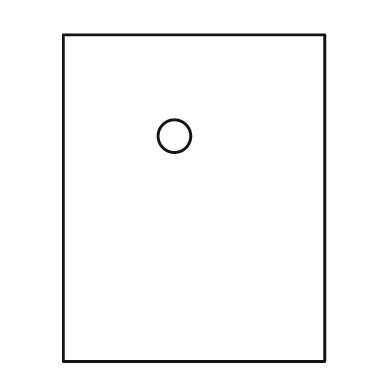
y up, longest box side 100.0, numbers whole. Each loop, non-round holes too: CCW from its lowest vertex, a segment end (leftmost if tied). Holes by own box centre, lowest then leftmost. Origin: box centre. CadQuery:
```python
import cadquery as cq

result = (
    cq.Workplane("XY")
    .moveTo(-40.0, -50.0)
    .lineTo(40.0, -50.0)
    .lineTo(40.0, 50.0)
    .lineTo(-40.0, 50.0)
    .close()
    .moveTo(-6.0, 19.0)
    .circle(5.0)
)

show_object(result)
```